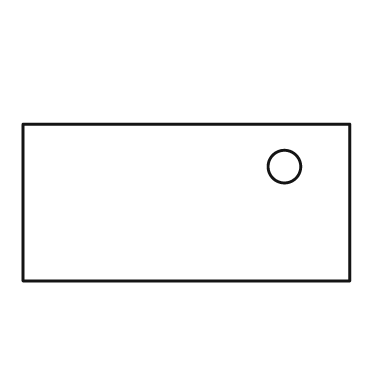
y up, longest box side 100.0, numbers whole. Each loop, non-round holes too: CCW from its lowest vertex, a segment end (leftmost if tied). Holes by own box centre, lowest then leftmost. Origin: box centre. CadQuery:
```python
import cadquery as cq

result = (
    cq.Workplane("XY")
    .moveTo(-50.0, -24.0)
    .lineTo(50.0, -24.0)
    .lineTo(50.0, 24.0)
    .lineTo(-50.0, 24.0)
    .close()
    .moveTo(30.0, 11.0)
    .circle(5.0)
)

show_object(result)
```